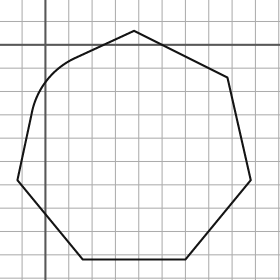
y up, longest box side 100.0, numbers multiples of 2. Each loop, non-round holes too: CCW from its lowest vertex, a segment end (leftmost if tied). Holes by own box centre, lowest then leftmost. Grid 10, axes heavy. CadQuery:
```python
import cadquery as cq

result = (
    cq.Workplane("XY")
    .moveTo(16.0, -92.0)
    .lineTo(60.0, -92.0)
    .lineTo(88.0, -58.0)
    .lineTo(78.0, -14.0)
    .lineTo(38.0, 6.0)
    .lineTo(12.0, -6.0)
    .threePointArc((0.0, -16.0), (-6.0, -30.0))
    .lineTo(-12.0, -58.0)
    .close()
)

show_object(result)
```